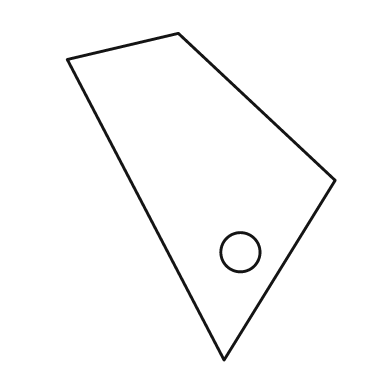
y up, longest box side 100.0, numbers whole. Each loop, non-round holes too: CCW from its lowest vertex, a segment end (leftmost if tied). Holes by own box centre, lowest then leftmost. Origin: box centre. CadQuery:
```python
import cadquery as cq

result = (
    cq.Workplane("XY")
    .moveTo(7.0, -50.0)
    .lineTo(41.0, 5.0)
    .lineTo(-7.0, 50.0)
    .lineTo(-41.0, 42.0)
    .close()
    .moveTo(12.0, -17.0)
    .circle(6.0)
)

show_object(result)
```